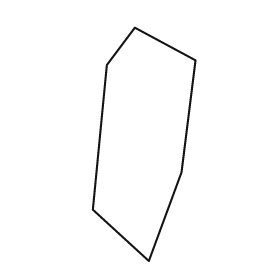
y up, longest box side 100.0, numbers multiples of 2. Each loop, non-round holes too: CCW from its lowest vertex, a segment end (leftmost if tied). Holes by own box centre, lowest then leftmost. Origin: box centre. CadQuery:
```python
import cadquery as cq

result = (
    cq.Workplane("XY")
    .moveTo(2.0, -50.0)
    .lineTo(16.0, -12.0)
    .lineTo(22.0, 36.0)
    .lineTo(-4.0, 50.0)
    .lineTo(-16.0, 34.0)
    .lineTo(-22.0, -28.0)
    .close()
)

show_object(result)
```